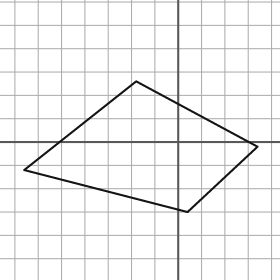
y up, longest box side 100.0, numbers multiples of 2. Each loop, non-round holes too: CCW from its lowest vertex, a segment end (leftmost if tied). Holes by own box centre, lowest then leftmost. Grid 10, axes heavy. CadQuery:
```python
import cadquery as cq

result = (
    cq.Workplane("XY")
    .moveTo(4.0, -30.0)
    .lineTo(34.0, -2.0)
    .lineTo(-18.0, 26.0)
    .lineTo(-66.0, -12.0)
    .close()
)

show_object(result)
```